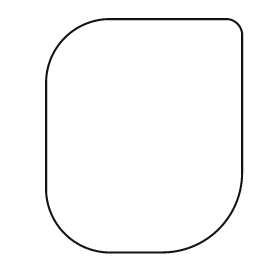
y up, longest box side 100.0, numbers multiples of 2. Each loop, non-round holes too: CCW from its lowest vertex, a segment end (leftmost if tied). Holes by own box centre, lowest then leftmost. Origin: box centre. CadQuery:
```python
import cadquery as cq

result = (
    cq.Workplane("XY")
    .moveTo(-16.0, -50.0)
    .lineTo(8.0, -50.0)
    .threePointArc((32.0, -40.0), (42.0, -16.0))
    .lineTo(42.0, 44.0)
    .threePointArc((40.0, 48.0), (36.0, 50.0))
    .lineTo(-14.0, 50.0)
    .threePointArc((-34.0, 42.0), (-42.0, 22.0))
    .lineTo(-42.0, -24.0)
    .threePointArc((-34.0, -42.0), (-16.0, -50.0))
    .close()
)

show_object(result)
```